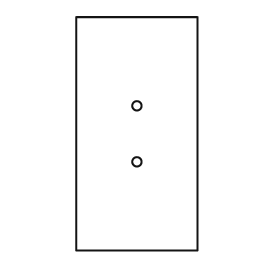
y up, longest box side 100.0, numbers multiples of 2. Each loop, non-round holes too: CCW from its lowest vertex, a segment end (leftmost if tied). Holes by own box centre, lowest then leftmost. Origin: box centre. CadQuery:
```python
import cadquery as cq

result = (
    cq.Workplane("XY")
    .moveTo(-26.0, -50.0)
    .lineTo(26.0, -50.0)
    .lineTo(26.0, 50.0)
    .lineTo(-26.0, 50.0)
    .close()
    .moveTo(0.0, -12.0)
    .circle(2.0)
    .moveTo(0.0, 12.0)
    .circle(2.0)
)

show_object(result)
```